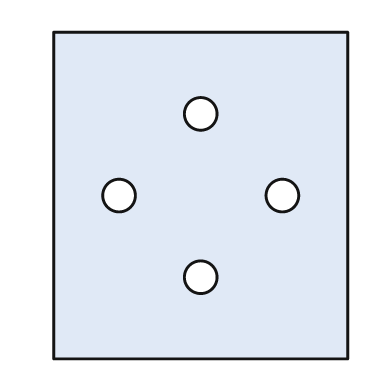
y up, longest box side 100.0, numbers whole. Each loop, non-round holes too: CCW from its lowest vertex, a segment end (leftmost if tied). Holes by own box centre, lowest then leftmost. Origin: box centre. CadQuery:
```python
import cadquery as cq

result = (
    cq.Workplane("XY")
    .moveTo(-45.0, -50.0)
    .lineTo(45.0, -50.0)
    .lineTo(45.0, 50.0)
    .lineTo(-45.0, 50.0)
    .close()
    .moveTo(0.0, -25.0)
    .circle(5.0)
    .moveTo(-25.0, 0.0)
    .circle(5.0)
    .moveTo(25.0, 0.0)
    .circle(5.0)
    .moveTo(0.0, 25.0)
    .circle(5.0)
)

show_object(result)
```